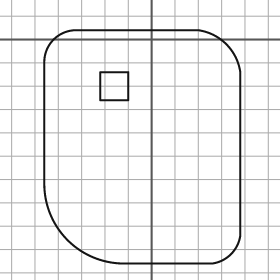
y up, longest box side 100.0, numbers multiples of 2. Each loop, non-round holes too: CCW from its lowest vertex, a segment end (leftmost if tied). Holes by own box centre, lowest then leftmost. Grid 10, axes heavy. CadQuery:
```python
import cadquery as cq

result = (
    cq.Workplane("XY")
    .moveTo(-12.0, -96.0)
    .lineTo(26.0, -96.0)
    .threePointArc((34.0, -92.0), (38.0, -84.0))
    .lineTo(38.0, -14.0)
    .threePointArc((32.0, -2.0), (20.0, 4.0))
    .lineTo(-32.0, 4.0)
    .threePointArc((-42.0, 0.0), (-46.0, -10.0))
    .lineTo(-46.0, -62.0)
    .threePointArc((-36.0, -86.0), (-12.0, -96.0))
    .close()
    .moveTo(-22.0, -26.0)
    .lineTo(-10.0, -26.0)
    .lineTo(-10.0, -14.0)
    .lineTo(-22.0, -14.0)
    .close()
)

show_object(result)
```